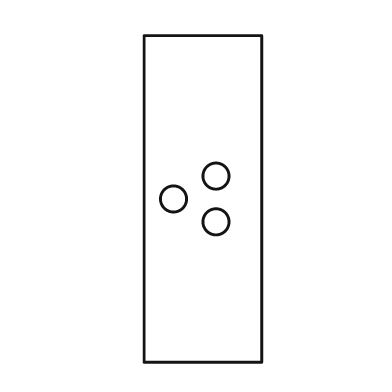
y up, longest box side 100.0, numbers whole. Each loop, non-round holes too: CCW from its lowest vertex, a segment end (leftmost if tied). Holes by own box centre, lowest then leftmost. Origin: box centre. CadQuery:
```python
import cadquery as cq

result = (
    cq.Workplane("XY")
    .moveTo(-18.0, -50.0)
    .lineTo(18.0, -50.0)
    .lineTo(18.0, 50.0)
    .lineTo(-18.0, 50.0)
    .close()
    .moveTo(4.0, -7.0)
    .circle(4.0)
    .moveTo(-9.0, 0.0)
    .circle(4.0)
    .moveTo(4.0, 7.0)
    .circle(4.0)
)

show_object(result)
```